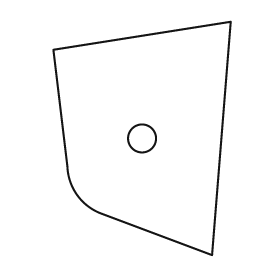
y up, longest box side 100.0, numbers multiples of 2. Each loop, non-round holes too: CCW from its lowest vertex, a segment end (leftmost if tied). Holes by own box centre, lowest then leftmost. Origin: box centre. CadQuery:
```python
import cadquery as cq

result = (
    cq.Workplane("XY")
    .moveTo(30.0, -50.0)
    .lineTo(38.0, 50.0)
    .lineTo(-38.0, 38.0)
    .lineTo(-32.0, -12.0)
    .threePointArc((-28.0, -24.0), (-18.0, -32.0))
    .close()
    .moveTo(0.0, 0.0)
    .circle(6.0)
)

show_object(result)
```